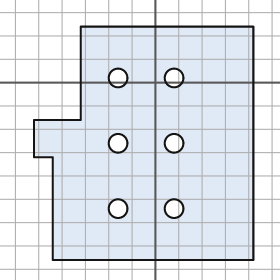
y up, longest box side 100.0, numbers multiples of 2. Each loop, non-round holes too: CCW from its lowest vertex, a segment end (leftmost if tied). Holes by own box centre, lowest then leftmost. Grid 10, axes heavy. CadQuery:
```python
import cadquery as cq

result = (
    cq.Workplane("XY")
    .moveTo(-44.0, -76.0)
    .lineTo(42.0, -76.0)
    .lineTo(42.0, 24.0)
    .lineTo(-32.0, 24.0)
    .lineTo(-32.0, -16.0)
    .lineTo(-52.0, -16.0)
    .lineTo(-52.0, -32.0)
    .lineTo(-44.0, -32.0)
    .close()
    .moveTo(-16.0, -54.0)
    .circle(4.0)
    .moveTo(8.0, -54.0)
    .circle(4.0)
    .moveTo(-16.0, -26.0)
    .circle(4.0)
    .moveTo(8.0, -26.0)
    .circle(4.0)
    .moveTo(-16.0, 2.0)
    .circle(4.0)
    .moveTo(8.0, 2.0)
    .circle(4.0)
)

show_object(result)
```